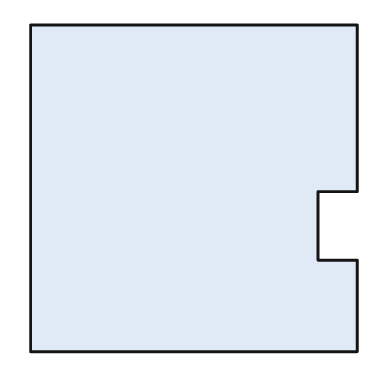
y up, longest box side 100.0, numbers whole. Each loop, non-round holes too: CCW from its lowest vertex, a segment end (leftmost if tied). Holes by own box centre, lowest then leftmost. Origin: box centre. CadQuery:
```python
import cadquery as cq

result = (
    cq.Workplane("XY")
    .moveTo(-50.0, -50.0)
    .lineTo(50.0, -50.0)
    .lineTo(50.0, -22.0)
    .lineTo(38.0, -22.0)
    .lineTo(38.0, -1.0)
    .lineTo(50.0, -1.0)
    .lineTo(50.0, 50.0)
    .lineTo(-50.0, 50.0)
    .close()
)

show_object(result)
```